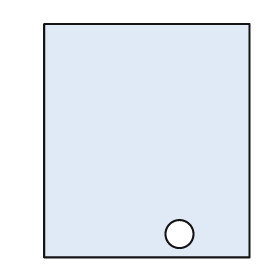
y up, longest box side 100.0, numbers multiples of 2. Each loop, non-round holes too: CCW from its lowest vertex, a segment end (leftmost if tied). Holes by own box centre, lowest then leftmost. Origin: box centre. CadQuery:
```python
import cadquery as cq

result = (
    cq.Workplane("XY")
    .moveTo(-44.0, -50.0)
    .lineTo(44.0, -50.0)
    .lineTo(44.0, 50.0)
    .lineTo(-44.0, 50.0)
    .close()
    .moveTo(14.0, -40.0)
    .circle(6.0)
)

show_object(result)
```